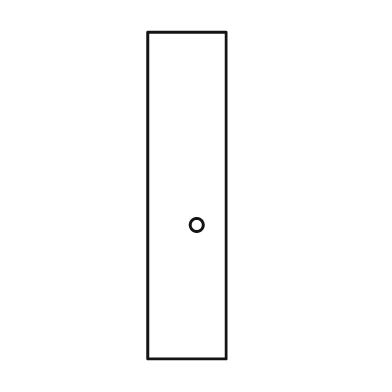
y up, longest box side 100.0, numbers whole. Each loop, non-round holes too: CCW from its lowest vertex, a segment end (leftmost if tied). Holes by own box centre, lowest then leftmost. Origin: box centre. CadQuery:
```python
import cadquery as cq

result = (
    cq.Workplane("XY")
    .moveTo(-12.0, -50.0)
    .lineTo(12.0, -50.0)
    .lineTo(12.0, 50.0)
    .lineTo(-12.0, 50.0)
    .close()
    .moveTo(3.0, -9.0)
    .circle(2.0)
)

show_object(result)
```